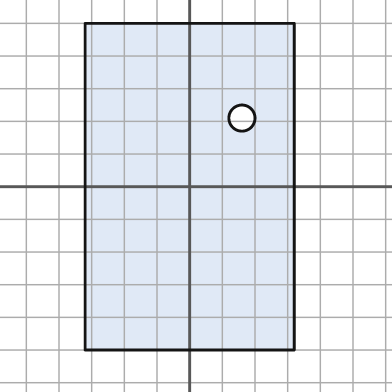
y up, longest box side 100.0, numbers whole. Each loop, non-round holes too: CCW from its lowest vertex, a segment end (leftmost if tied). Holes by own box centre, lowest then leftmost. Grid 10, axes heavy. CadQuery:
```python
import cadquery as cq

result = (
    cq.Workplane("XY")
    .moveTo(-32.0, -50.0)
    .lineTo(32.0, -50.0)
    .lineTo(32.0, 50.0)
    .lineTo(-32.0, 50.0)
    .close()
    .moveTo(16.0, 21.0)
    .circle(4.0)
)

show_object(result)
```